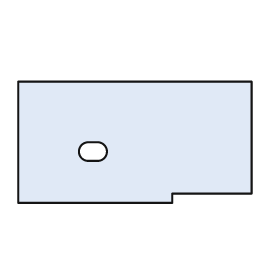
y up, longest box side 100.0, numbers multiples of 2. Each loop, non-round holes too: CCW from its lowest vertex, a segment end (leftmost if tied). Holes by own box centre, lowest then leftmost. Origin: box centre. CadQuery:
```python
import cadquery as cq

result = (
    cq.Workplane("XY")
    .moveTo(-50.0, -26.0)
    .lineTo(16.0, -26.0)
    .lineTo(16.0, -22.0)
    .lineTo(50.0, -22.0)
    .lineTo(50.0, 26.0)
    .lineTo(-50.0, 26.0)
    .close()
    .moveTo(-20.0, -8.0)
    .lineTo(-16.0, -8.0)
    .threePointArc((-12.0, -4.0), (-16.0, 0.0))
    .lineTo(-20.0, 0.0)
    .threePointArc((-24.0, -4.0), (-20.0, -8.0))
    .close()
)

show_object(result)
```